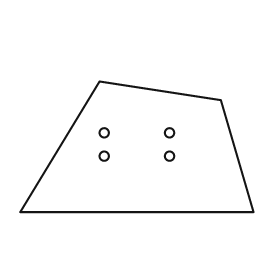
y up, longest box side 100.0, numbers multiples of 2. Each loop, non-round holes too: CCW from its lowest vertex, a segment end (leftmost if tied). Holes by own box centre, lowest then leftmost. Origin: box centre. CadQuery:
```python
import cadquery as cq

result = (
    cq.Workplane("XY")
    .moveTo(-50.0, -28.0)
    .lineTo(50.0, -28.0)
    .lineTo(36.0, 20.0)
    .lineTo(-16.0, 28.0)
    .close()
    .moveTo(-14.0, -4.0)
    .circle(2.0)
    .moveTo(14.0, -4.0)
    .circle(2.0)
    .moveTo(-14.0, 6.0)
    .circle(2.0)
    .moveTo(14.0, 6.0)
    .circle(2.0)
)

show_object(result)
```